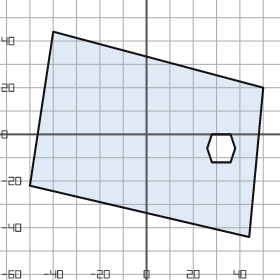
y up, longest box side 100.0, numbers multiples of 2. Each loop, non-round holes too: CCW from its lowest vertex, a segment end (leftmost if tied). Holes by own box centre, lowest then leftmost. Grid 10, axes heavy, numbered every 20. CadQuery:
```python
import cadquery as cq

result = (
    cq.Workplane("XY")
    .moveTo(44.0, -44.0)
    .lineTo(50.0, 20.0)
    .lineTo(-40.0, 44.0)
    .lineTo(-50.0, -22.0)
    .close()
    .moveTo(28.0, -12.0)
    .lineTo(36.0, -12.0)
    .lineTo(38.0, -6.0)
    .lineTo(36.0, 0.0)
    .lineTo(28.0, 0.0)
    .lineTo(26.0, -6.0)
    .close()
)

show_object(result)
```